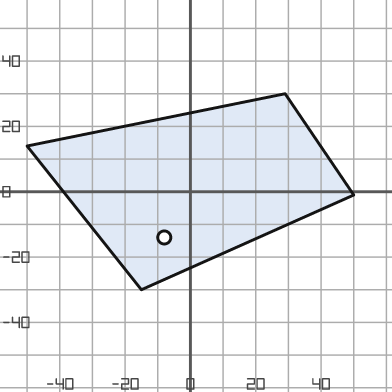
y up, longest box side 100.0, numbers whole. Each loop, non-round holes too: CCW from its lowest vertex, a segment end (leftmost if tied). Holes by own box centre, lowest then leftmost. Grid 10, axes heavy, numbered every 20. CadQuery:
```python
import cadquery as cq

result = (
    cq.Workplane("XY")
    .moveTo(-15.0, -30.0)
    .lineTo(50.0, -1.0)
    .lineTo(29.0, 30.0)
    .lineTo(-50.0, 14.0)
    .close()
    .moveTo(-8.0, -14.0)
    .circle(2.0)
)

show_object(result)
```